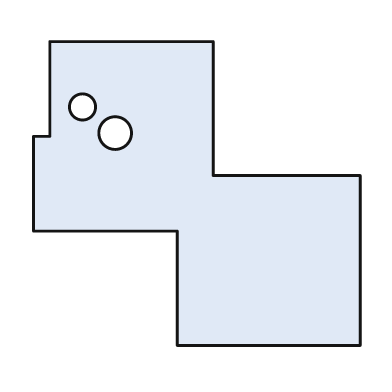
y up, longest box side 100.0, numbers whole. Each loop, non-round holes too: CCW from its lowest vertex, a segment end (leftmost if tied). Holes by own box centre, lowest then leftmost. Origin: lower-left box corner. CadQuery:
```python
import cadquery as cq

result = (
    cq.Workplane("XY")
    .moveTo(44.0, 0.0)
    .lineTo(100.0, 0.0)
    .lineTo(100.0, 52.0)
    .lineTo(55.0, 52.0)
    .lineTo(55.0, 93.0)
    .lineTo(5.0, 93.0)
    .lineTo(5.0, 64.0)
    .lineTo(0.0, 64.0)
    .lineTo(0.0, 35.0)
    .lineTo(44.0, 35.0)
    .close()
    .moveTo(25.0, 65.0)
    .circle(5.0)
    .moveTo(15.0, 73.0)
    .circle(4.0)
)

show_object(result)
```